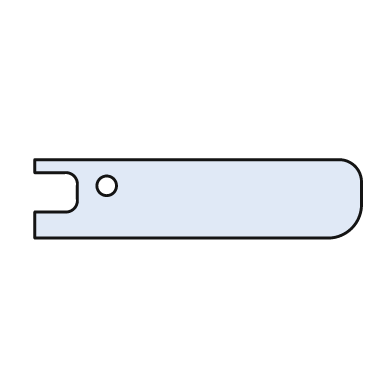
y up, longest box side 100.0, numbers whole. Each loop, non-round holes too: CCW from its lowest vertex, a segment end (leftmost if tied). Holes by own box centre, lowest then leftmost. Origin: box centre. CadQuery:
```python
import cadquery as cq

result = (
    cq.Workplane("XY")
    .moveTo(-50.0, -12.0)
    .lineTo(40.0, -12.0)
    .threePointArc((47.0, -9.0), (50.0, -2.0))
    .lineTo(50.0, 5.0)
    .threePointArc((48.0, 10.0), (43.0, 12.0))
    .lineTo(-50.0, 12.0)
    .lineTo(-50.0, 8.0)
    .lineTo(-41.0, 8.0)
    .threePointArc((-38.0, 7.0), (-37.0, 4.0))
    .lineTo(-37.0, 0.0)
    .threePointArc((-38.0, -3.0), (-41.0, -4.0))
    .lineTo(-50.0, -4.0)
    .close()
    .moveTo(-28.0, 4.0)
    .circle(3.0)
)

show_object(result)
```